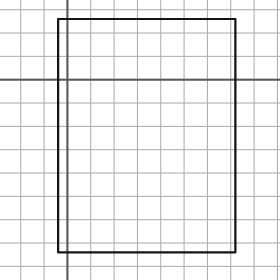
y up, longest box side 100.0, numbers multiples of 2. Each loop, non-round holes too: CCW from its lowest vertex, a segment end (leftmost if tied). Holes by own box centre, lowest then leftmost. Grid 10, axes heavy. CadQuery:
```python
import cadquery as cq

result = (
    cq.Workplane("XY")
    .moveTo(-4.0, -74.0)
    .lineTo(72.0, -74.0)
    .lineTo(72.0, 26.0)
    .lineTo(-4.0, 26.0)
    .close()
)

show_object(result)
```